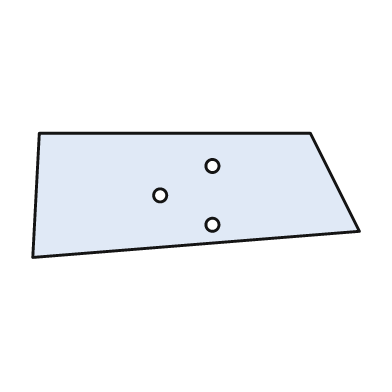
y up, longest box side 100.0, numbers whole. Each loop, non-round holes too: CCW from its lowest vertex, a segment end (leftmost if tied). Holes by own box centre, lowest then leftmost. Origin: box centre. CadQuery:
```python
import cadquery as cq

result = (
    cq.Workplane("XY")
    .moveTo(-50.0, -19.0)
    .lineTo(50.0, -11.0)
    .lineTo(35.0, 19.0)
    .lineTo(-48.0, 19.0)
    .close()
    .moveTo(5.0, -9.0)
    .circle(2.0)
    .moveTo(-11.0, 0.0)
    .circle(2.0)
    .moveTo(5.0, 9.0)
    .circle(2.0)
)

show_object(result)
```